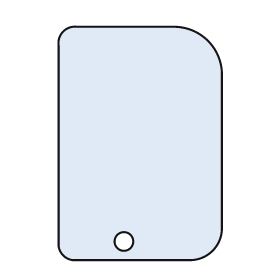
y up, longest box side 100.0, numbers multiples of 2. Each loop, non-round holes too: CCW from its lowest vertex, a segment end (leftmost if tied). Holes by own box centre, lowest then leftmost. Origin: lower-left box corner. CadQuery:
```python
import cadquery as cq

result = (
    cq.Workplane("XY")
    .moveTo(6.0, 0.0)
    .lineTo(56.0, 0.0)
    .threePointArc((66.0, 4.0), (70.0, 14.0))
    .lineTo(70.0, 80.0)
    .threePointArc((64.0, 94.0), (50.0, 100.0))
    .lineTo(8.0, 100.0)
    .threePointArc((2.0, 98.0), (0.0, 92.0))
    .lineTo(0.0, 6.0)
    .threePointArc((2.0, 2.0), (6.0, 0.0))
    .close()
    .moveTo(28.0, 8.0)
    .circle(4.0)
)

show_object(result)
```